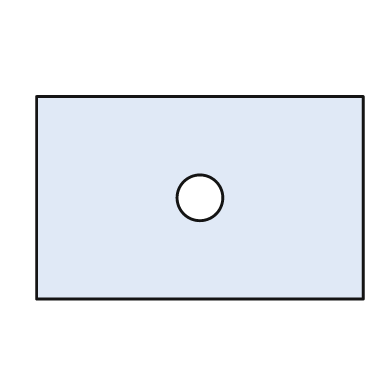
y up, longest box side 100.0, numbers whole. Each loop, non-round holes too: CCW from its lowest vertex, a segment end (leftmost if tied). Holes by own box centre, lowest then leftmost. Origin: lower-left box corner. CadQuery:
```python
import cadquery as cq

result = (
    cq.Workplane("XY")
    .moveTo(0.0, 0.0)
    .lineTo(100.0, 0.0)
    .lineTo(100.0, 62.0)
    .lineTo(0.0, 62.0)
    .close()
    .moveTo(50.0, 31.0)
    .circle(7.0)
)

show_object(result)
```